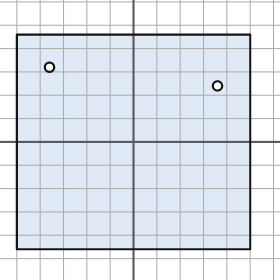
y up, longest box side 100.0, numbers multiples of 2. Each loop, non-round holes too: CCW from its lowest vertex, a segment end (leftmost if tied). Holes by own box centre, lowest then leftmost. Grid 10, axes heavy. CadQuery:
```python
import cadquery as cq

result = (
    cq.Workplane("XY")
    .moveTo(-50.0, -46.0)
    .lineTo(50.0, -46.0)
    .lineTo(50.0, 46.0)
    .lineTo(-50.0, 46.0)
    .close()
    .moveTo(36.0, 24.0)
    .circle(2.0)
    .moveTo(-36.0, 32.0)
    .circle(2.0)
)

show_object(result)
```